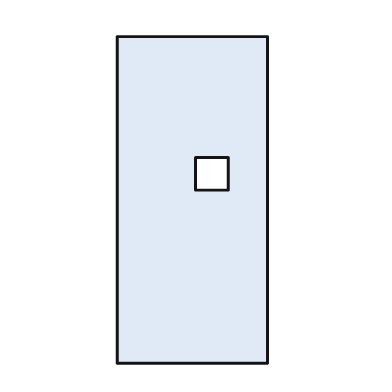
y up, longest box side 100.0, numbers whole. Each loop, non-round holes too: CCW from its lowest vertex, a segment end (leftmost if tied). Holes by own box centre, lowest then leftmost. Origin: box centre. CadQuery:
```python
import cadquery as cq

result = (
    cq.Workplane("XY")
    .moveTo(-23.0, -50.0)
    .lineTo(23.0, -50.0)
    .lineTo(23.0, 50.0)
    .lineTo(-23.0, 50.0)
    .close()
    .moveTo(1.0, 3.0)
    .lineTo(11.0, 3.0)
    .lineTo(11.0, 13.0)
    .lineTo(1.0, 13.0)
    .close()
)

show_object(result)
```